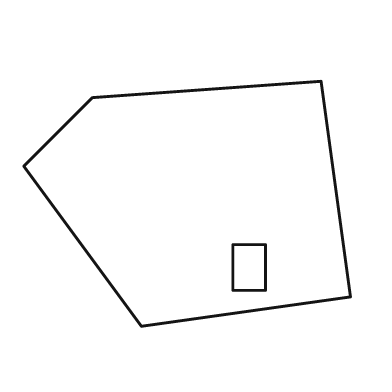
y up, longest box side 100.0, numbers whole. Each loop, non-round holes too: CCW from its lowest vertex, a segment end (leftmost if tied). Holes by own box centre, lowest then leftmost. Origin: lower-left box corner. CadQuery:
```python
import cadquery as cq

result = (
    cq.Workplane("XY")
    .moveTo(36.0, 0.0)
    .lineTo(100.0, 9.0)
    .lineTo(91.0, 75.0)
    .lineTo(21.0, 70.0)
    .lineTo(0.0, 49.0)
    .close()
    .moveTo(64.0, 11.0)
    .lineTo(74.0, 11.0)
    .lineTo(74.0, 25.0)
    .lineTo(64.0, 25.0)
    .close()
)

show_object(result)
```